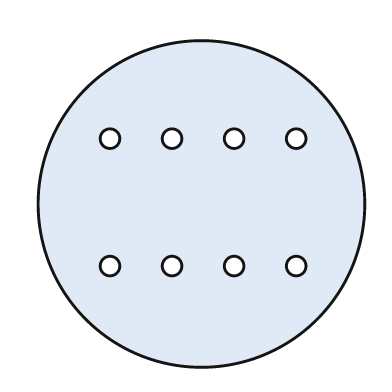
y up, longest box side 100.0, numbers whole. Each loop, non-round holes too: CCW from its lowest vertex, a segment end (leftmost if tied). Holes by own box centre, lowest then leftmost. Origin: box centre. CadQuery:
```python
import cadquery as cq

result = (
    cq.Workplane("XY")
    .moveTo(0.0, 0.0)
    .circle(50.0)
    .moveTo(-28.0, -19.0)
    .circle(3.0)
    .moveTo(-9.0, -19.0)
    .circle(3.0)
    .moveTo(10.0, -19.0)
    .circle(3.0)
    .moveTo(29.0, -19.0)
    .circle(3.0)
    .moveTo(-28.0, 20.0)
    .circle(3.0)
    .moveTo(-9.0, 20.0)
    .circle(3.0)
    .moveTo(10.0, 20.0)
    .circle(3.0)
    .moveTo(29.0, 20.0)
    .circle(3.0)
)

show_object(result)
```